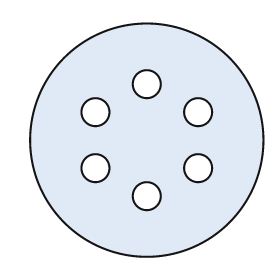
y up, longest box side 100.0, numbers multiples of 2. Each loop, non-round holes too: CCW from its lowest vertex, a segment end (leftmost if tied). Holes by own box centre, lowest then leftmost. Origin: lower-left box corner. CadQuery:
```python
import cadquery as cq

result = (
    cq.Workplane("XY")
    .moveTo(50.0, 50.0)
    .circle(50.0)
    .moveTo(50.0, 26.0)
    .circle(6.0)
    .moveTo(28.0, 38.0)
    .circle(6.0)
    .moveTo(72.0, 38.0)
    .circle(6.0)
    .moveTo(28.0, 62.0)
    .circle(6.0)
    .moveTo(72.0, 62.0)
    .circle(6.0)
    .moveTo(50.0, 74.0)
    .circle(6.0)
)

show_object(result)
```